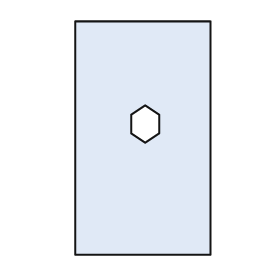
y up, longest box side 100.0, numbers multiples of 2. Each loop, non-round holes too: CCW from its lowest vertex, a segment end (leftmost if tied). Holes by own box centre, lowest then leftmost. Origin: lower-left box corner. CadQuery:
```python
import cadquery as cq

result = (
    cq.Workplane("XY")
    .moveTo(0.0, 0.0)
    .lineTo(58.0, 0.0)
    .lineTo(58.0, 100.0)
    .lineTo(0.0, 100.0)
    .close()
    .moveTo(30.0, 48.0)
    .lineTo(36.0, 52.0)
    .lineTo(36.0, 60.0)
    .lineTo(30.0, 64.0)
    .lineTo(24.0, 60.0)
    .lineTo(24.0, 52.0)
    .close()
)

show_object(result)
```